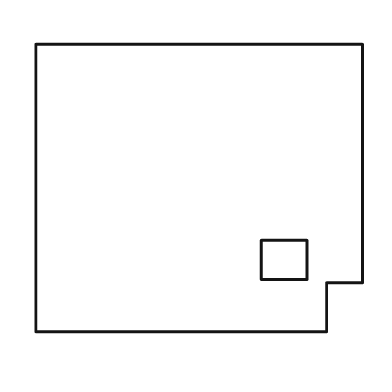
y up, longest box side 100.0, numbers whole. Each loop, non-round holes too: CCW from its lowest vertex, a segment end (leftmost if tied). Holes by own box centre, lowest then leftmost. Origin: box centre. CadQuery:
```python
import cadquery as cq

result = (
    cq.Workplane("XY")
    .moveTo(-50.0, -44.0)
    .lineTo(39.0, -44.0)
    .lineTo(39.0, -29.0)
    .lineTo(50.0, -29.0)
    .lineTo(50.0, 44.0)
    .lineTo(-50.0, 44.0)
    .close()
    .moveTo(19.0, -28.0)
    .lineTo(33.0, -28.0)
    .lineTo(33.0, -16.0)
    .lineTo(19.0, -16.0)
    .close()
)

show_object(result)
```